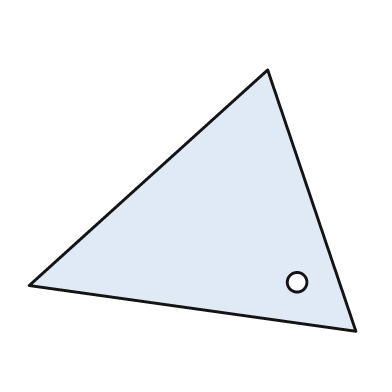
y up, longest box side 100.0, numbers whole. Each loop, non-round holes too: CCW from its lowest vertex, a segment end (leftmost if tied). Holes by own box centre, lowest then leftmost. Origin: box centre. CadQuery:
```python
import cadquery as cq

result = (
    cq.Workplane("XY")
    .moveTo(50.0, -40.0)
    .lineTo(23.0, 40.0)
    .lineTo(-50.0, -26.0)
    .close()
    .moveTo(32.0, -25.0)
    .circle(3.0)
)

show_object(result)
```